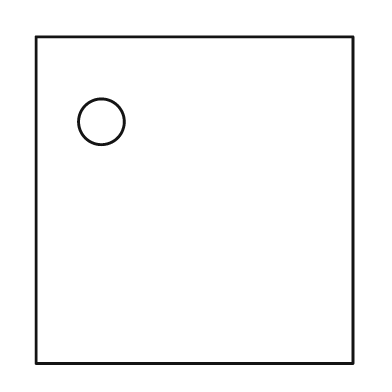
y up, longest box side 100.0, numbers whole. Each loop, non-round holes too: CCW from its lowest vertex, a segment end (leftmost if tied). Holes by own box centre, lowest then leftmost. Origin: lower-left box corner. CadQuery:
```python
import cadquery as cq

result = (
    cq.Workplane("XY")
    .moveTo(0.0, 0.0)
    .lineTo(97.0, 0.0)
    .lineTo(97.0, 100.0)
    .lineTo(0.0, 100.0)
    .close()
    .moveTo(20.0, 74.0)
    .circle(7.0)
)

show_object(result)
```